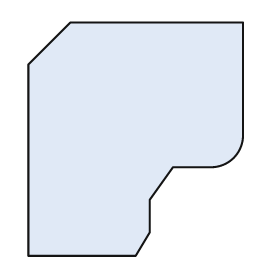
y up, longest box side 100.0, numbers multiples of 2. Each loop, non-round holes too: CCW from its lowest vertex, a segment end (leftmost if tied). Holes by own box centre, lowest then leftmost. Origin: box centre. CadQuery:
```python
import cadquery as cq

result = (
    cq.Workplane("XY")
    .moveTo(-46.0, -50.0)
    .lineTo(0.0, -50.0)
    .lineTo(6.0, -40.0)
    .lineTo(6.0, -26.0)
    .lineTo(16.0, -12.0)
    .lineTo(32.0, -12.0)
    .threePointArc((42.0, -8.0), (46.0, 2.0))
    .lineTo(46.0, 50.0)
    .lineTo(-28.0, 50.0)
    .lineTo(-46.0, 32.0)
    .close()
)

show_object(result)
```